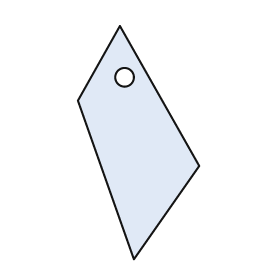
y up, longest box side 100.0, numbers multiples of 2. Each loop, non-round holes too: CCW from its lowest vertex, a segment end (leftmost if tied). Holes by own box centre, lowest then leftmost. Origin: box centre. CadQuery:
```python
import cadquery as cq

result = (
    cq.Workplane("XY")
    .moveTo(-2.0, -50.0)
    .lineTo(26.0, -10.0)
    .lineTo(-8.0, 50.0)
    .lineTo(-26.0, 18.0)
    .close()
    .moveTo(-6.0, 28.0)
    .circle(4.0)
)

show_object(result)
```